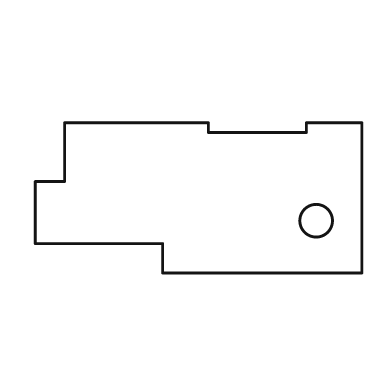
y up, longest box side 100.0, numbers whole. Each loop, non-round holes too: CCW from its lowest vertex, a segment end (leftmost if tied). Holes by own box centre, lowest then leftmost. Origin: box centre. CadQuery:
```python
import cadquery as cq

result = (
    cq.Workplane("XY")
    .moveTo(-11.0, -23.0)
    .lineTo(50.0, -23.0)
    .lineTo(50.0, 23.0)
    .lineTo(33.0, 23.0)
    .lineTo(33.0, 20.0)
    .lineTo(3.0, 20.0)
    .lineTo(3.0, 23.0)
    .lineTo(-41.0, 23.0)
    .lineTo(-41.0, 5.0)
    .lineTo(-50.0, 5.0)
    .lineTo(-50.0, -14.0)
    .lineTo(-11.0, -14.0)
    .close()
    .moveTo(36.0, -7.0)
    .circle(5.0)
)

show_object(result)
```